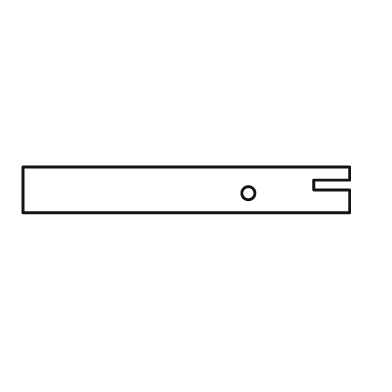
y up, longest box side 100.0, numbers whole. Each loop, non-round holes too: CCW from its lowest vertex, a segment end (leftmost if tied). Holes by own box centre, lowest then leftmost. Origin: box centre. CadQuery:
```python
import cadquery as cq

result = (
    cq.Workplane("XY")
    .moveTo(-50.0, -7.0)
    .lineTo(50.0, -7.0)
    .lineTo(50.0, 0.0)
    .lineTo(39.0, 0.0)
    .lineTo(39.0, 3.0)
    .lineTo(50.0, 3.0)
    .lineTo(50.0, 7.0)
    .lineTo(-50.0, 7.0)
    .close()
    .moveTo(19.0, -1.0)
    .circle(2.0)
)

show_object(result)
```